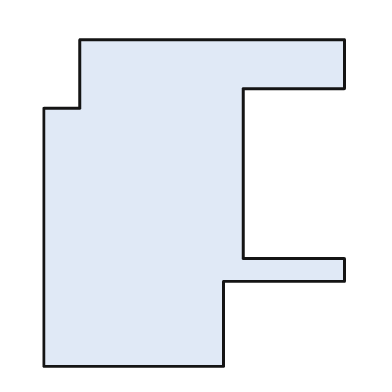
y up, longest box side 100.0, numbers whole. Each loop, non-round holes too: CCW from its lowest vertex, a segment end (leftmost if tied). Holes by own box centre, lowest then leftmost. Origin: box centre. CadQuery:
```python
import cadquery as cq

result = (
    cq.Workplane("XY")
    .moveTo(-46.0, -50.0)
    .lineTo(9.0, -50.0)
    .lineTo(9.0, -24.0)
    .lineTo(46.0, -24.0)
    .lineTo(46.0, -17.0)
    .lineTo(15.0, -17.0)
    .lineTo(15.0, 35.0)
    .lineTo(46.0, 35.0)
    .lineTo(46.0, 50.0)
    .lineTo(-35.0, 50.0)
    .lineTo(-35.0, 29.0)
    .lineTo(-46.0, 29.0)
    .close()
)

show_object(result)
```